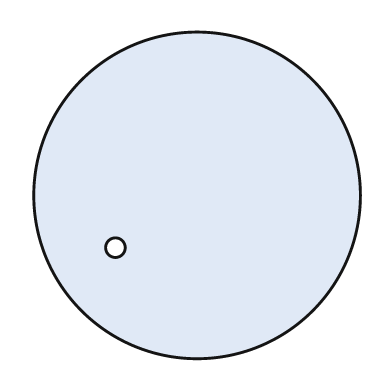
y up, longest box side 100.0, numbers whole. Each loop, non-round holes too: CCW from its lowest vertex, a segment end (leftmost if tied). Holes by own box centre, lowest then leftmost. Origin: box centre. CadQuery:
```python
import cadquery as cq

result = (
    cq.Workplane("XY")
    .moveTo(0.0, 0.0)
    .circle(50.0)
    .moveTo(-25.0, -16.0)
    .circle(3.0)
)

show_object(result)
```